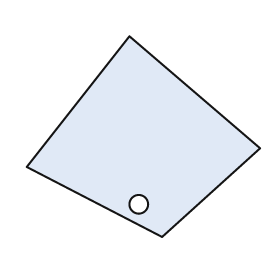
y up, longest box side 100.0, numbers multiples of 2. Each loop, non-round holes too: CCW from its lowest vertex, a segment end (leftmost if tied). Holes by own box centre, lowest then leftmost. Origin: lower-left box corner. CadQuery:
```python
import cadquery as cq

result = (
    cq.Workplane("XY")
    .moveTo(58.0, 0.0)
    .lineTo(100.0, 38.0)
    .lineTo(44.0, 86.0)
    .lineTo(0.0, 30.0)
    .close()
    .moveTo(48.0, 14.0)
    .circle(4.0)
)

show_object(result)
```